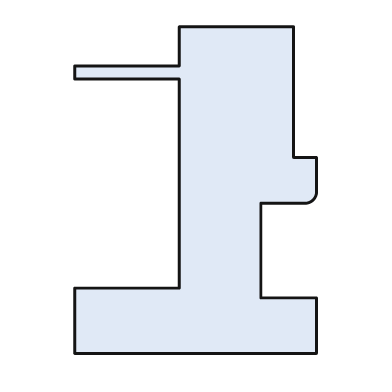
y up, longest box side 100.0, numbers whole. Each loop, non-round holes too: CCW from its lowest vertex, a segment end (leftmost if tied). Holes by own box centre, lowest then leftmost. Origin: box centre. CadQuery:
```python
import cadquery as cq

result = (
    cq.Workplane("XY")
    .moveTo(-37.0, -50.0)
    .lineTo(37.0, -50.0)
    .lineTo(37.0, -33.0)
    .lineTo(20.0, -33.0)
    .lineTo(20.0, -4.0)
    .lineTo(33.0, -4.0)
    .threePointArc((36.0, -3.0), (37.0, 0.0))
    .lineTo(37.0, 10.0)
    .lineTo(30.0, 10.0)
    .lineTo(30.0, 50.0)
    .lineTo(-5.0, 50.0)
    .lineTo(-5.0, 38.0)
    .lineTo(-37.0, 38.0)
    .lineTo(-37.0, 34.0)
    .lineTo(-5.0, 34.0)
    .lineTo(-5.0, -30.0)
    .lineTo(-37.0, -30.0)
    .close()
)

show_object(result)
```